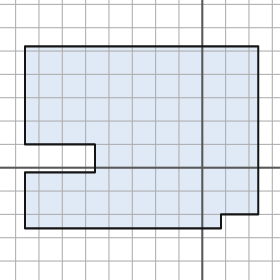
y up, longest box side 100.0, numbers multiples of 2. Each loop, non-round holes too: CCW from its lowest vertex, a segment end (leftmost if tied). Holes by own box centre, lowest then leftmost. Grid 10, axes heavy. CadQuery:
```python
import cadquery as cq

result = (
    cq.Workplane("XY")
    .moveTo(-76.0, -26.0)
    .lineTo(8.0, -26.0)
    .lineTo(8.0, -20.0)
    .lineTo(24.0, -20.0)
    .lineTo(24.0, 52.0)
    .lineTo(-76.0, 52.0)
    .lineTo(-76.0, 10.0)
    .lineTo(-46.0, 10.0)
    .lineTo(-46.0, -2.0)
    .lineTo(-76.0, -2.0)
    .close()
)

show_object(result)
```